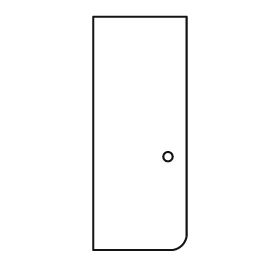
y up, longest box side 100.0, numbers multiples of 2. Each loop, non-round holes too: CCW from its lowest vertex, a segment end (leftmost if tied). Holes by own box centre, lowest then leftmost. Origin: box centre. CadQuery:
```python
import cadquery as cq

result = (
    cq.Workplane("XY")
    .moveTo(-20.0, -50.0)
    .lineTo(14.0, -50.0)
    .threePointArc((18.0, -48.0), (20.0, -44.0))
    .lineTo(20.0, 50.0)
    .lineTo(-20.0, 50.0)
    .close()
    .moveTo(12.0, -10.0)
    .circle(2.0)
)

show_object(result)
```